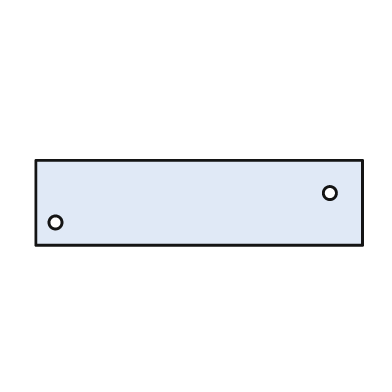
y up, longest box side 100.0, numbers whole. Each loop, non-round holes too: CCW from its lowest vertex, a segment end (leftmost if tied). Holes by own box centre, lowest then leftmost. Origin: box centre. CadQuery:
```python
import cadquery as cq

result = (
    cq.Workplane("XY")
    .moveTo(-50.0, -13.0)
    .lineTo(50.0, -13.0)
    .lineTo(50.0, 13.0)
    .lineTo(-50.0, 13.0)
    .close()
    .moveTo(-44.0, -6.0)
    .circle(2.0)
    .moveTo(40.0, 3.0)
    .circle(2.0)
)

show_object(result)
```